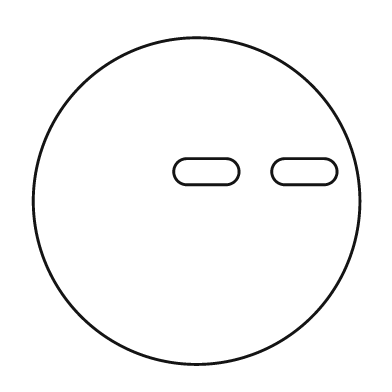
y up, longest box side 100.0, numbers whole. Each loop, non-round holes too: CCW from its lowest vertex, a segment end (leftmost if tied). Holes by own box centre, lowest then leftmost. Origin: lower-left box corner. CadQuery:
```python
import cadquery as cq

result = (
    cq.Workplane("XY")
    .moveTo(50.0, 50.0)
    .circle(50.0)
    .moveTo(47.0, 55.0)
    .lineTo(59.0, 55.0)
    .threePointArc((63.0, 59.0), (59.0, 63.0))
    .lineTo(47.0, 63.0)
    .threePointArc((43.0, 59.0), (47.0, 55.0))
    .close()
    .moveTo(77.0, 55.0)
    .lineTo(89.0, 55.0)
    .threePointArc((93.0, 59.0), (89.0, 63.0))
    .lineTo(77.0, 63.0)
    .threePointArc((73.0, 59.0), (77.0, 55.0))
    .close()
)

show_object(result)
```